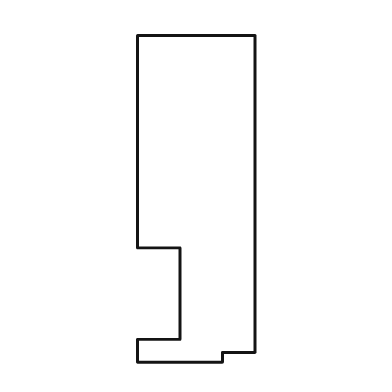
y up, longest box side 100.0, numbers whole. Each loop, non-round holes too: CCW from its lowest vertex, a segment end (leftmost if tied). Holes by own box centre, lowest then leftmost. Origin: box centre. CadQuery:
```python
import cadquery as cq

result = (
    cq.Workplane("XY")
    .moveTo(-18.0, -50.0)
    .lineTo(8.0, -50.0)
    .lineTo(8.0, -47.0)
    .lineTo(18.0, -47.0)
    .lineTo(18.0, 50.0)
    .lineTo(-18.0, 50.0)
    .lineTo(-18.0, -15.0)
    .lineTo(-5.0, -15.0)
    .lineTo(-5.0, -43.0)
    .lineTo(-18.0, -43.0)
    .close()
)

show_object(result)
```